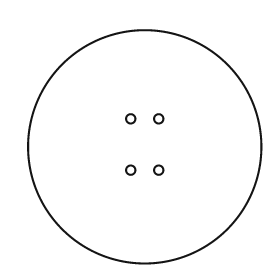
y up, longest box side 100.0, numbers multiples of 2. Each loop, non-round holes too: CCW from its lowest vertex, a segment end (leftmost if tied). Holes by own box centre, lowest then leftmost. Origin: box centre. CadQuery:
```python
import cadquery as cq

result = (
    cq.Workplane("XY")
    .moveTo(0.0, 0.0)
    .circle(50.0)
    .moveTo(-6.0, -10.0)
    .circle(2.0)
    .moveTo(6.0, -10.0)
    .circle(2.0)
    .moveTo(-6.0, 12.0)
    .circle(2.0)
    .moveTo(6.0, 12.0)
    .circle(2.0)
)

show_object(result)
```